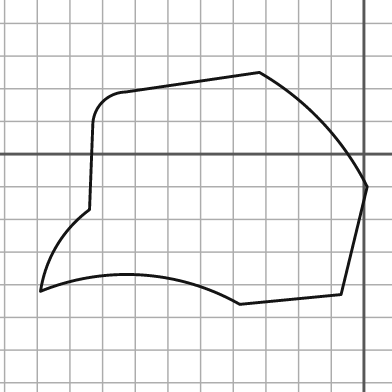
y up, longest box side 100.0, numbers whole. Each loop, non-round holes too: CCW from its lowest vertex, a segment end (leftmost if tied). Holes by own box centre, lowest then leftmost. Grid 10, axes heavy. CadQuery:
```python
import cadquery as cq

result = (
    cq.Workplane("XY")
    .moveTo(-38.0, -46.0)
    .lineTo(-7.0, -43.0)
    .lineTo(1.0, -10.0)
    .threePointArc((-13.0, 10.0), (-32.0, 25.0))
    .lineTo(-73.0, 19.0)
    .threePointArc((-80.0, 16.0), (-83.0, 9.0))
    .lineTo(-84.0, -17.0)
    .threePointArc((-94.0, -28.0), (-99.0, -42.0))
    .threePointArc((-68.0, -37.0), (-38.0, -46.0))
    .close()
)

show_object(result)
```